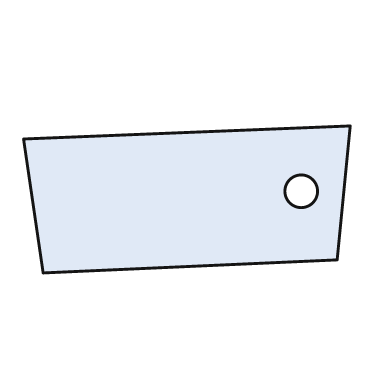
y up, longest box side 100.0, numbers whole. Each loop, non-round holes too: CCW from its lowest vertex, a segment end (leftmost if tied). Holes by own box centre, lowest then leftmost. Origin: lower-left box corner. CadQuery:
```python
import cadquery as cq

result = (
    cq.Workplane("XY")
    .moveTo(6.0, 0.0)
    .lineTo(96.0, 4.0)
    .lineTo(100.0, 45.0)
    .lineTo(0.0, 41.0)
    .close()
    .moveTo(85.0, 25.0)
    .circle(5.0)
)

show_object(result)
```